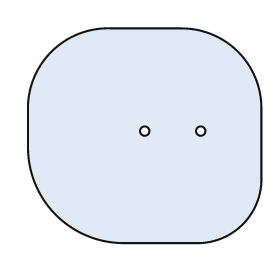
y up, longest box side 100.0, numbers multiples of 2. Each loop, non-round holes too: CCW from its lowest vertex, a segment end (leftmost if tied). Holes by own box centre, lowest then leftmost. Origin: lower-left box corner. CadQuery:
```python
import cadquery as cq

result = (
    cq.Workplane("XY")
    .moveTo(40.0, 0.0)
    .lineTo(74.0, 0.0)
    .threePointArc((92.0, 8.0), (100.0, 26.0))
    .lineTo(100.0, 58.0)
    .threePointArc((90.0, 82.0), (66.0, 92.0))
    .lineTo(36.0, 92.0)
    .threePointArc((10.0, 82.0), (0.0, 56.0))
    .lineTo(0.0, 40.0)
    .threePointArc((12.0, 12.0), (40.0, 0.0))
    .close()
    .moveTo(50.0, 48.0)
    .circle(2.0)
    .moveTo(74.0, 48.0)
    .circle(2.0)
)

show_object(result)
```